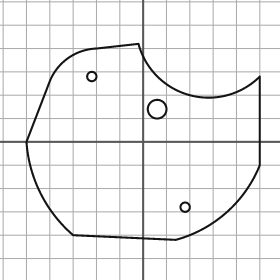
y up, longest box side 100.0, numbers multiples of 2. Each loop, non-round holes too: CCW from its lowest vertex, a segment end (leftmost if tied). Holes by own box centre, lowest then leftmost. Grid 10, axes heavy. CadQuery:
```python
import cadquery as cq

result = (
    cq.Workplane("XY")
    .moveTo(14.0, -42.0)
    .threePointArc((36.0, -30.0), (50.0, -10.0))
    .lineTo(50.0, 28.0)
    .threePointArc((20.0, 20.0), (-2.0, 42.0))
    .lineTo(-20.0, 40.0)
    .threePointArc((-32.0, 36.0), (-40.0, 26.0))
    .lineTo(-50.0, 0.0)
    .threePointArc((-44.0, -22.0), (-30.0, -40.0))
    .close()
    .moveTo(18.0, -28.0)
    .circle(2.0)
    .moveTo(6.0, 14.0)
    .circle(4.0)
    .moveTo(-22.0, 28.0)
    .circle(2.0)
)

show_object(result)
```